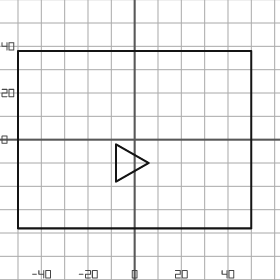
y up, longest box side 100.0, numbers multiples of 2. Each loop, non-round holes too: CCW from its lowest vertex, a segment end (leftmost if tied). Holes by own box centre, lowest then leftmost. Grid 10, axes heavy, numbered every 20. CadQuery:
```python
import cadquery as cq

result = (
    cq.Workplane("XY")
    .moveTo(-50.0, -38.0)
    .lineTo(50.0, -38.0)
    .lineTo(50.0, 38.0)
    .lineTo(-50.0, 38.0)
    .close()
    .moveTo(-8.0, -18.0)
    .lineTo(6.0, -10.0)
    .lineTo(-8.0, -2.0)
    .close()
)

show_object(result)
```